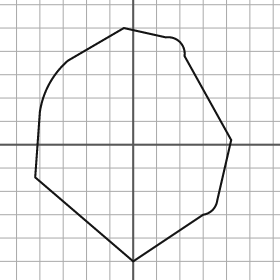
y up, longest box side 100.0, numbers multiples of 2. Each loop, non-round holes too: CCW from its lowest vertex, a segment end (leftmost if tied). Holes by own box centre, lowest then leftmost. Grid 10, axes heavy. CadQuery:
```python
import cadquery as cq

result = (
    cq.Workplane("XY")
    .moveTo(0.0, -50.0)
    .lineTo(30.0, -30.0)
    .threePointArc((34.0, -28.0), (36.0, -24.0))
    .lineTo(42.0, 2.0)
    .lineTo(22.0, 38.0)
    .threePointArc((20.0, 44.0), (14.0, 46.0))
    .lineTo(-4.0, 50.0)
    .lineTo(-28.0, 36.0)
    .threePointArc((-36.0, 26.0), (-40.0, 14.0))
    .lineTo(-42.0, -14.0)
    .close()
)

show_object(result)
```